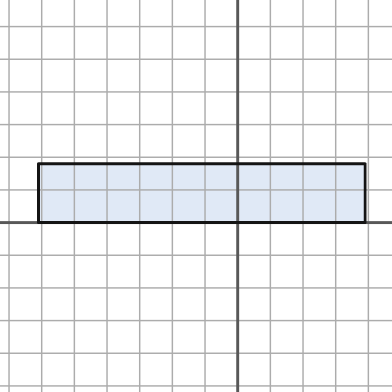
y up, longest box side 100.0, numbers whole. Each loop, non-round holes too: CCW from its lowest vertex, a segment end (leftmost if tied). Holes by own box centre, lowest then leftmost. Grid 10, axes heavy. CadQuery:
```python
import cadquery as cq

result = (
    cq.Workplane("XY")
    .moveTo(-61.0, 0.0)
    .lineTo(39.0, 0.0)
    .lineTo(39.0, 18.0)
    .lineTo(-61.0, 18.0)
    .close()
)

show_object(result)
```